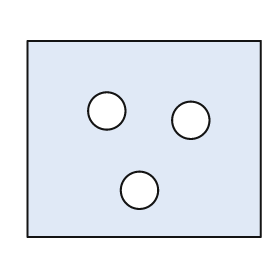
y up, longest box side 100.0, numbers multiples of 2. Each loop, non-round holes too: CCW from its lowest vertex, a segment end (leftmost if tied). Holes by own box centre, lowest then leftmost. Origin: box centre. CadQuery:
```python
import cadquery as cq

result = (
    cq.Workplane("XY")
    .moveTo(-50.0, -42.0)
    .lineTo(50.0, -42.0)
    .lineTo(50.0, 42.0)
    .lineTo(-50.0, 42.0)
    .close()
    .moveTo(-2.0, -22.0)
    .circle(8.0)
    .moveTo(20.0, 8.0)
    .circle(8.0)
    .moveTo(-16.0, 12.0)
    .circle(8.0)
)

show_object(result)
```